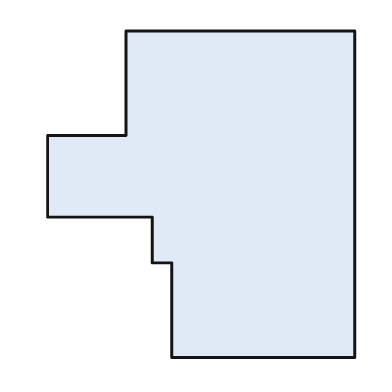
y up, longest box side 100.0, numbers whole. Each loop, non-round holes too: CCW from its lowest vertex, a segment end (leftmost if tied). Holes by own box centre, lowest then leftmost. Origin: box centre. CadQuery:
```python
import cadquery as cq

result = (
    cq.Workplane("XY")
    .moveTo(-9.0, -50.0)
    .lineTo(47.0, -50.0)
    .lineTo(47.0, 50.0)
    .lineTo(-23.0, 50.0)
    .lineTo(-23.0, 18.0)
    .lineTo(-47.0, 18.0)
    .lineTo(-47.0, -7.0)
    .lineTo(-15.0, -7.0)
    .lineTo(-15.0, -21.0)
    .lineTo(-9.0, -21.0)
    .close()
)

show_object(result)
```